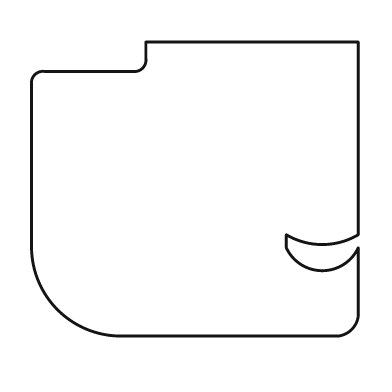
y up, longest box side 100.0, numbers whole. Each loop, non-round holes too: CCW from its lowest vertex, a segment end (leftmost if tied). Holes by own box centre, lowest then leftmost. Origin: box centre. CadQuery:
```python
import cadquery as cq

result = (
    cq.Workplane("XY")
    .moveTo(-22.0, -45.0)
    .lineTo(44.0, -45.0)
    .threePointArc((48.0, -43.0), (50.0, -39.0))
    .lineTo(50.0, -18.0)
    .threePointArc((39.0, -25.0), (28.0, -18.0))
    .lineTo(28.0, -14.0)
    .threePointArc((39.0, -17.0), (50.0, -14.0))
    .lineTo(50.0, 45.0)
    .lineTo(-15.0, 45.0)
    .lineTo(-15.0, 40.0)
    .threePointArc((-16.0, 37.0), (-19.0, 36.0))
    .lineTo(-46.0, 36.0)
    .threePointArc((-49.0, 35.0), (-50.0, 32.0))
    .lineTo(-50.0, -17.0)
    .threePointArc((-42.0, -37.0), (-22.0, -45.0))
    .close()
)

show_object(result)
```